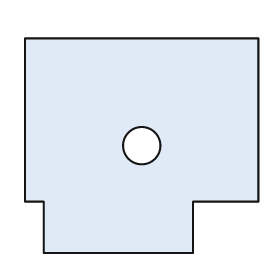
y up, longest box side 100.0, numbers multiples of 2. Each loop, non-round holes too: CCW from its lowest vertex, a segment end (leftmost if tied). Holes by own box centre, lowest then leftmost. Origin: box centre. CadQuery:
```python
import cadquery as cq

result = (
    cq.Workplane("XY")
    .moveTo(-42.0, -46.0)
    .lineTo(22.0, -46.0)
    .lineTo(22.0, -24.0)
    .lineTo(50.0, -24.0)
    .lineTo(50.0, 46.0)
    .lineTo(-50.0, 46.0)
    .lineTo(-50.0, -24.0)
    .lineTo(-42.0, -24.0)
    .close()
    .moveTo(0.0, 0.0)
    .circle(8.0)
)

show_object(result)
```